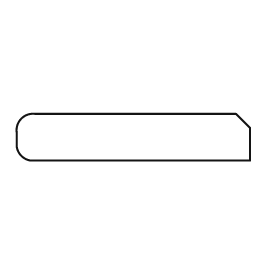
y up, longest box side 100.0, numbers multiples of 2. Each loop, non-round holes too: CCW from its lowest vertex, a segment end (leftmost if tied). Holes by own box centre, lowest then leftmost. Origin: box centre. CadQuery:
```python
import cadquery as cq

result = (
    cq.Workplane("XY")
    .moveTo(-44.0, -10.0)
    .lineTo(50.0, -10.0)
    .lineTo(50.0, 4.0)
    .lineTo(44.0, 10.0)
    .lineTo(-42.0, 10.0)
    .threePointArc((-48.0, 8.0), (-50.0, 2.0))
    .lineTo(-50.0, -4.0)
    .threePointArc((-48.0, -8.0), (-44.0, -10.0))
    .close()
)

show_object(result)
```